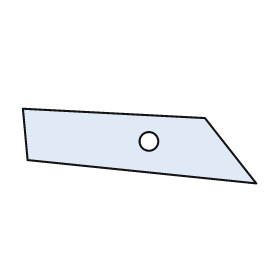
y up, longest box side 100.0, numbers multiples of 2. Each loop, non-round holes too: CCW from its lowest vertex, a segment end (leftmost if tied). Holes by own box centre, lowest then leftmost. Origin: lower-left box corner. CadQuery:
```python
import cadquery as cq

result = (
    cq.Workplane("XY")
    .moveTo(100.0, 0.0)
    .lineTo(78.0, 28.0)
    .lineTo(0.0, 32.0)
    .lineTo(2.0, 10.0)
    .close()
    .moveTo(54.0, 18.0)
    .circle(4.0)
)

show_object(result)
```